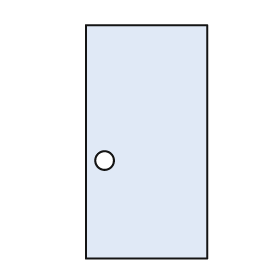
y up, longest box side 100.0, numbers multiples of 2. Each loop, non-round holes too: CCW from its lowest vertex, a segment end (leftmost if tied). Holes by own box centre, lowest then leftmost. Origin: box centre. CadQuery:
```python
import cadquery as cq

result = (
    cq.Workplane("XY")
    .moveTo(-26.0, -50.0)
    .lineTo(26.0, -50.0)
    .lineTo(26.0, 50.0)
    .lineTo(-26.0, 50.0)
    .close()
    .moveTo(-18.0, -8.0)
    .circle(4.0)
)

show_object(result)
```